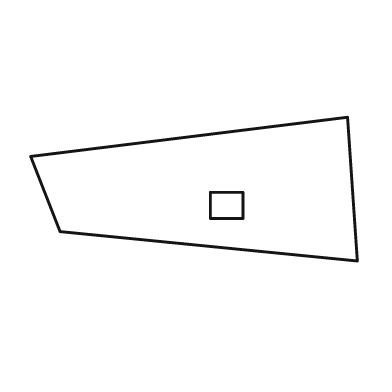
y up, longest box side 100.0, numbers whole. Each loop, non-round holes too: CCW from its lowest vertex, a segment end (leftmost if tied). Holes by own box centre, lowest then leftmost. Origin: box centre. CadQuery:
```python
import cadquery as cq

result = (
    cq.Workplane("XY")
    .moveTo(50.0, -22.0)
    .lineTo(47.0, 22.0)
    .lineTo(-50.0, 10.0)
    .lineTo(-41.0, -13.0)
    .close()
    .moveTo(5.0, -9.0)
    .lineTo(15.0, -9.0)
    .lineTo(15.0, -1.0)
    .lineTo(5.0, -1.0)
    .close()
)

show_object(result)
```